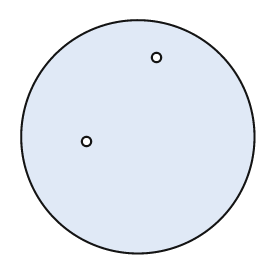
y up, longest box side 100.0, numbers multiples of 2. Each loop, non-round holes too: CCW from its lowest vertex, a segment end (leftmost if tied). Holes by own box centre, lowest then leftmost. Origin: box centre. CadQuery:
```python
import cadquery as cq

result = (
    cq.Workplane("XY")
    .moveTo(0.0, 0.0)
    .circle(50.0)
    .moveTo(-22.0, -2.0)
    .circle(2.0)
    .moveTo(8.0, 34.0)
    .circle(2.0)
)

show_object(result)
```